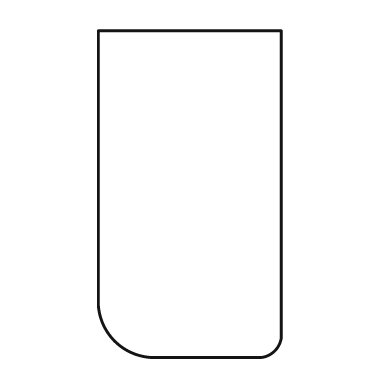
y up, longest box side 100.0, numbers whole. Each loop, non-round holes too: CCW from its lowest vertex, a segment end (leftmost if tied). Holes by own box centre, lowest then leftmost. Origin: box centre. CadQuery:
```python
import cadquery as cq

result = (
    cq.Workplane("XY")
    .moveTo(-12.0, -50.0)
    .lineTo(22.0, -50.0)
    .threePointArc((26.0, -48.0), (28.0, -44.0))
    .lineTo(28.0, 50.0)
    .lineTo(-28.0, 50.0)
    .lineTo(-28.0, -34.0)
    .threePointArc((-23.0, -45.0), (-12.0, -50.0))
    .close()
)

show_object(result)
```